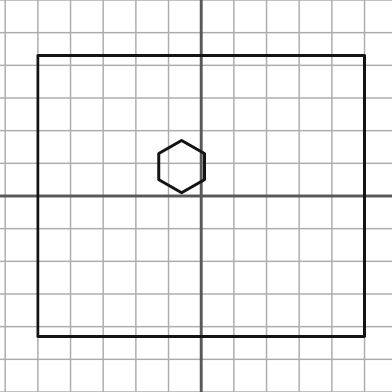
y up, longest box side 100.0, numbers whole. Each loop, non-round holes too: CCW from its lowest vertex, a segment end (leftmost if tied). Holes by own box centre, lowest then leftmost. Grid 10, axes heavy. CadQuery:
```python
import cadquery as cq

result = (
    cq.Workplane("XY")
    .moveTo(-50.0, -43.0)
    .lineTo(50.0, -43.0)
    .lineTo(50.0, 43.0)
    .lineTo(-50.0, 43.0)
    .close()
    .moveTo(-6.0, 1.0)
    .lineTo(1.0, 5.0)
    .lineTo(1.0, 13.0)
    .lineTo(-6.0, 17.0)
    .lineTo(-13.0, 13.0)
    .lineTo(-13.0, 5.0)
    .close()
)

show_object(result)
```